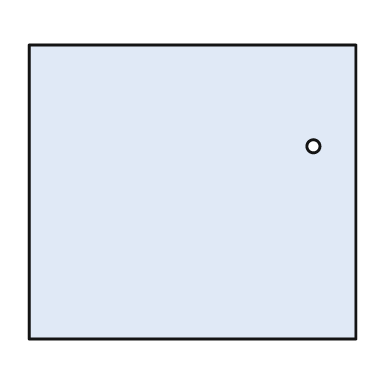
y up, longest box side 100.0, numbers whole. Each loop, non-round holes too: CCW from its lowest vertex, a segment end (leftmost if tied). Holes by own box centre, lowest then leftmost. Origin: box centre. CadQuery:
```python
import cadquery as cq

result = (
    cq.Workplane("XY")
    .moveTo(-50.0, -45.0)
    .lineTo(50.0, -45.0)
    .lineTo(50.0, 45.0)
    .lineTo(-50.0, 45.0)
    .close()
    .moveTo(37.0, 14.0)
    .circle(2.0)
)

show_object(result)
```